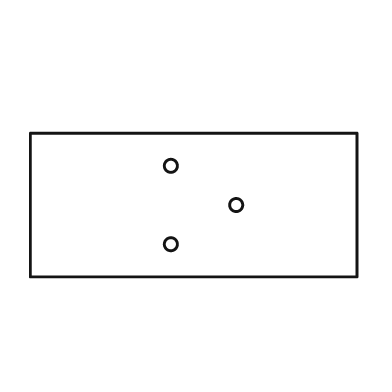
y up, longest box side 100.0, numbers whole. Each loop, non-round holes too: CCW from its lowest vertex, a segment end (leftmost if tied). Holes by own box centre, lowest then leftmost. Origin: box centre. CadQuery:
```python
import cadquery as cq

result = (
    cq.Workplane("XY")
    .moveTo(-50.0, -22.0)
    .lineTo(50.0, -22.0)
    .lineTo(50.0, 22.0)
    .lineTo(-50.0, 22.0)
    .close()
    .moveTo(-7.0, -12.0)
    .circle(2.0)
    .moveTo(13.0, 0.0)
    .circle(2.0)
    .moveTo(-7.0, 12.0)
    .circle(2.0)
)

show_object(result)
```